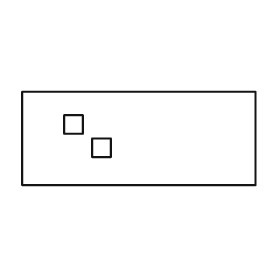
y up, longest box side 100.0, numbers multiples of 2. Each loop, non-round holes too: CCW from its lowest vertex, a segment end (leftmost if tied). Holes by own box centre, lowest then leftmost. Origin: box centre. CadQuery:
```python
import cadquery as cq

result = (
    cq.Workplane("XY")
    .moveTo(-50.0, -20.0)
    .lineTo(50.0, -20.0)
    .lineTo(50.0, 20.0)
    .lineTo(-50.0, 20.0)
    .close()
    .moveTo(-20.0, -8.0)
    .lineTo(-12.0, -8.0)
    .lineTo(-12.0, 0.0)
    .lineTo(-20.0, 0.0)
    .close()
    .moveTo(-32.0, 2.0)
    .lineTo(-24.0, 2.0)
    .lineTo(-24.0, 10.0)
    .lineTo(-32.0, 10.0)
    .close()
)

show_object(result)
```